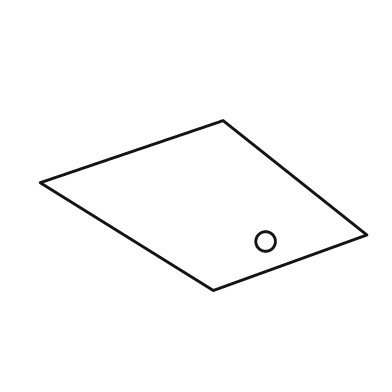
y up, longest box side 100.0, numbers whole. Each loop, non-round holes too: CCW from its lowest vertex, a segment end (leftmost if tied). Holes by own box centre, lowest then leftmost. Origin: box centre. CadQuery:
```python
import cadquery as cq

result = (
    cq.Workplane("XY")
    .moveTo(3.0, -26.0)
    .lineTo(50.0, -9.0)
    .lineTo(6.0, 26.0)
    .lineTo(-50.0, 7.0)
    .close()
    .moveTo(19.0, -11.0)
    .circle(3.0)
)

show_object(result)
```